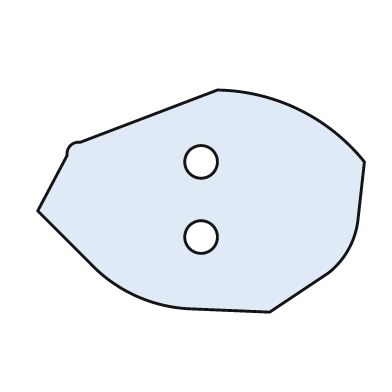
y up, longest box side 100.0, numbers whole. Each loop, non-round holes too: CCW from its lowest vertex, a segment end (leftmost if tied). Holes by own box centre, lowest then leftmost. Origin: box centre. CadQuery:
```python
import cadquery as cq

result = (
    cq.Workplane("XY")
    .moveTo(21.0, -34.0)
    .lineTo(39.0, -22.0)
    .threePointArc((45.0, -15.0), (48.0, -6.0))
    .lineTo(50.0, 12.0)
    .threePointArc((30.0, 28.0), (5.0, 34.0))
    .lineTo(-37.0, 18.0)
    .threePointArc((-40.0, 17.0), (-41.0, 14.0))
    .lineTo(-50.0, -3.0)
    .lineTo(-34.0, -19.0)
    .threePointArc((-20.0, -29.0), (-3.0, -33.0))
    .close()
    .moveTo(0.0, -11.0)
    .circle(5.0)
    .moveTo(0.0, 12.0)
    .circle(5.0)
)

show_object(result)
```